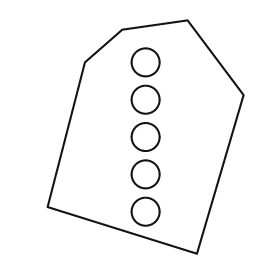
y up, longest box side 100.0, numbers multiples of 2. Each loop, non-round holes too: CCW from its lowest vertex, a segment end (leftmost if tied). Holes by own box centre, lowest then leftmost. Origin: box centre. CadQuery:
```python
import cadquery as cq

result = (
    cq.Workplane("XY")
    .moveTo(22.0, -50.0)
    .lineTo(42.0, 18.0)
    .lineTo(18.0, 50.0)
    .lineTo(-10.0, 46.0)
    .lineTo(-26.0, 32.0)
    .lineTo(-42.0, -30.0)
    .close()
    .moveTo(0.0, -32.0)
    .circle(6.0)
    .moveTo(0.0, -16.0)
    .circle(6.0)
    .moveTo(0.0, 0.0)
    .circle(6.0)
    .moveTo(0.0, 16.0)
    .circle(6.0)
    .moveTo(0.0, 32.0)
    .circle(6.0)
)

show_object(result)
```